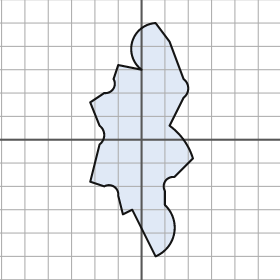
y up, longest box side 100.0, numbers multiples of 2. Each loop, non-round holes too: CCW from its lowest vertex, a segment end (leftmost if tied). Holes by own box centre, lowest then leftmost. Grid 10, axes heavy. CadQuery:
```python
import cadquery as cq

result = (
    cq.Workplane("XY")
    .moveTo(6.0, -50.0)
    .threePointArc((14.0, -40.0), (10.0, -28.0))
    .lineTo(10.0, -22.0)
    .threePointArc((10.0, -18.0), (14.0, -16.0))
    .lineTo(22.0, -8.0)
    .threePointArc((18.0, 0.0), (12.0, 6.0))
    .lineTo(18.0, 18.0)
    .threePointArc((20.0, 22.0), (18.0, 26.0))
    .lineTo(12.0, 42.0)
    .lineTo(6.0, 50.0)
    .threePointArc((-4.0, 42.0), (0.0, 30.0))
    .lineTo(-10.0, 32.0)
    .lineTo(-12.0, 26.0)
    .threePointArc((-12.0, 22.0), (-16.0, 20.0))
    .lineTo(-22.0, 16.0)
    .lineTo(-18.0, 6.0)
    .threePointArc((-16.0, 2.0), (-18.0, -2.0))
    .lineTo(-22.0, -18.0)
    .lineTo(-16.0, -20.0)
    .threePointArc((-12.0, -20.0), (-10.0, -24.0))
    .lineTo(-8.0, -32.0)
    .lineTo(-4.0, -30.0)
    .close()
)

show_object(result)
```